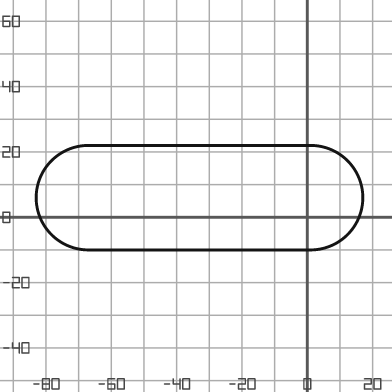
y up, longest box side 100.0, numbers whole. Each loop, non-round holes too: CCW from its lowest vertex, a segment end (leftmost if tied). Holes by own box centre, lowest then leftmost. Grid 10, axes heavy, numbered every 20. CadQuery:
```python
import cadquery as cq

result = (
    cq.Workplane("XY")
    .moveTo(-67.0, -10.0)
    .lineTo(1.0, -10.0)
    .threePointArc((17.0, 6.0), (1.0, 22.0))
    .lineTo(-67.0, 22.0)
    .threePointArc((-83.0, 6.0), (-67.0, -10.0))
    .close()
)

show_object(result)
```